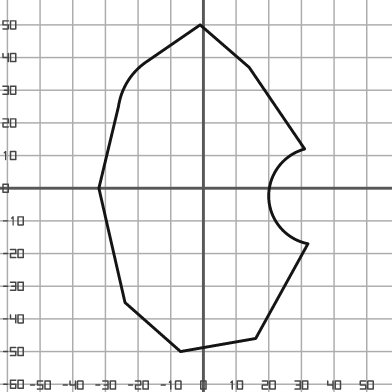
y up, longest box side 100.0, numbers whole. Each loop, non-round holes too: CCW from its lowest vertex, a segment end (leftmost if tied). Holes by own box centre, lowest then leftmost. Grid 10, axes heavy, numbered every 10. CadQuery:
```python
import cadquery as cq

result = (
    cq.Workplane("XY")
    .moveTo(-7.0, -50.0)
    .lineTo(16.0, -46.0)
    .lineTo(32.0, -17.0)
    .threePointArc((20.0, -3.0), (31.0, 12.0))
    .lineTo(14.0, 37.0)
    .lineTo(-1.0, 50.0)
    .lineTo(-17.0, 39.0)
    .threePointArc((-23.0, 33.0), (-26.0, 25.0))
    .lineTo(-32.0, 0.0)
    .lineTo(-24.0, -35.0)
    .close()
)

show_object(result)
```